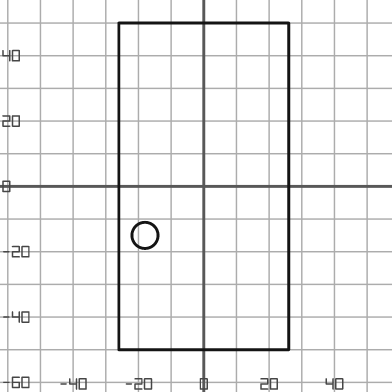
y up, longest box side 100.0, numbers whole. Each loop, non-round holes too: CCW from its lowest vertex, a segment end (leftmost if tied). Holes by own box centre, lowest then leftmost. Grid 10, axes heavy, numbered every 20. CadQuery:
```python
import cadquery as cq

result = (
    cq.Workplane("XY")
    .moveTo(-26.0, -50.0)
    .lineTo(26.0, -50.0)
    .lineTo(26.0, 50.0)
    .lineTo(-26.0, 50.0)
    .close()
    .moveTo(-18.0, -15.0)
    .circle(4.0)
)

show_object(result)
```